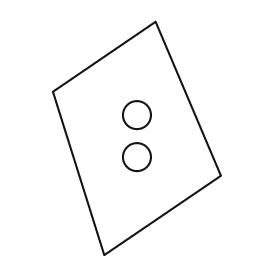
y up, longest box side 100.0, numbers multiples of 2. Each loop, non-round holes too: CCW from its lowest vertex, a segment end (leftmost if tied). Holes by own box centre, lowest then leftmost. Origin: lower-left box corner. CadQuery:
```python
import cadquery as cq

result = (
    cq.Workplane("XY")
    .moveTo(22.0, 0.0)
    .lineTo(72.0, 34.0)
    .lineTo(44.0, 100.0)
    .lineTo(0.0, 70.0)
    .close()
    .moveTo(36.0, 42.0)
    .circle(6.0)
    .moveTo(36.0, 60.0)
    .circle(6.0)
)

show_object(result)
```